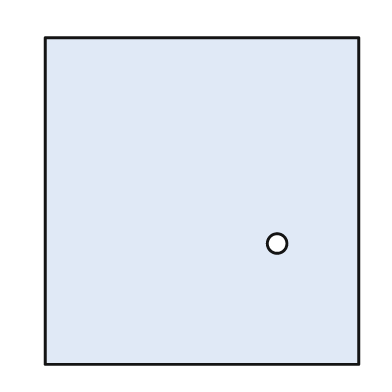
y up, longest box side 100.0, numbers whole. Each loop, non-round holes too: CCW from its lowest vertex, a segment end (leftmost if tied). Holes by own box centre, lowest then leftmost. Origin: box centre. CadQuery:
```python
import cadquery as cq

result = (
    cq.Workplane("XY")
    .moveTo(-48.0, -50.0)
    .lineTo(48.0, -50.0)
    .lineTo(48.0, 50.0)
    .lineTo(-48.0, 50.0)
    .close()
    .moveTo(23.0, -13.0)
    .circle(3.0)
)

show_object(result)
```